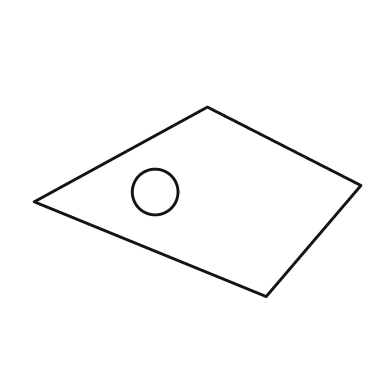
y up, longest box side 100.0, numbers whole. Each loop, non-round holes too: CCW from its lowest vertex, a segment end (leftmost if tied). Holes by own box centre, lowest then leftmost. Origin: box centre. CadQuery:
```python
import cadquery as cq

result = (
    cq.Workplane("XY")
    .moveTo(21.0, -29.0)
    .lineTo(50.0, 5.0)
    .lineTo(3.0, 29.0)
    .lineTo(-50.0, 0.0)
    .close()
    .moveTo(-13.0, 3.0)
    .circle(7.0)
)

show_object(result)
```